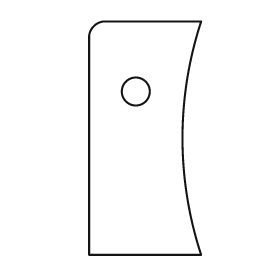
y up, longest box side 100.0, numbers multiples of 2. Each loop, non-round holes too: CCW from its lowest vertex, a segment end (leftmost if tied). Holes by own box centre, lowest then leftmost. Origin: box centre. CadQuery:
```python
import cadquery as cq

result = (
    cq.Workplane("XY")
    .moveTo(-24.0, -50.0)
    .lineTo(24.0, -50.0)
    .threePointArc((16.0, 0.0), (24.0, 50.0))
    .lineTo(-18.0, 50.0)
    .threePointArc((-22.0, 48.0), (-24.0, 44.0))
    .close()
    .moveTo(-4.0, 20.0)
    .circle(6.0)
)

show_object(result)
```